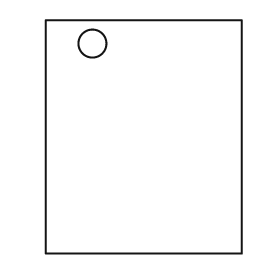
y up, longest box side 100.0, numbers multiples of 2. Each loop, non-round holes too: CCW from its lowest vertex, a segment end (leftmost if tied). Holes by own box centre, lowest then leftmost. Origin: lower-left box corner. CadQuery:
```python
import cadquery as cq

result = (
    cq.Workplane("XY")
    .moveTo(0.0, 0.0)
    .lineTo(84.0, 0.0)
    .lineTo(84.0, 100.0)
    .lineTo(0.0, 100.0)
    .close()
    .moveTo(20.0, 90.0)
    .circle(6.0)
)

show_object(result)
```